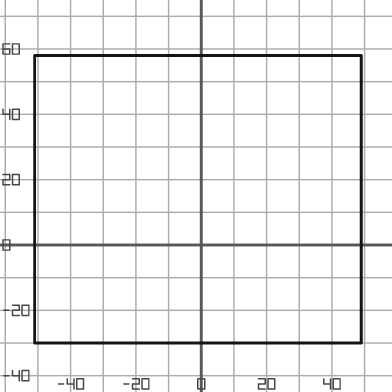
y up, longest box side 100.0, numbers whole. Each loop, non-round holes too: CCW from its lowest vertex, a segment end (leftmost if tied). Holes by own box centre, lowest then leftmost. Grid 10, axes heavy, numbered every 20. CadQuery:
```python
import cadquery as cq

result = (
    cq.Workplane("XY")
    .moveTo(-51.0, -30.0)
    .lineTo(49.0, -30.0)
    .lineTo(49.0, 58.0)
    .lineTo(-51.0, 58.0)
    .close()
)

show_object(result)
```